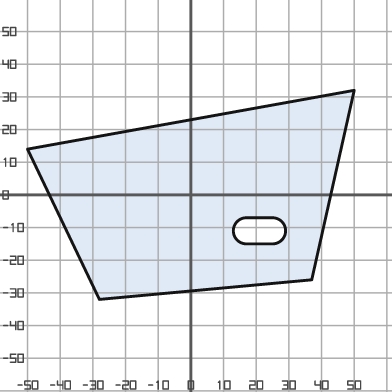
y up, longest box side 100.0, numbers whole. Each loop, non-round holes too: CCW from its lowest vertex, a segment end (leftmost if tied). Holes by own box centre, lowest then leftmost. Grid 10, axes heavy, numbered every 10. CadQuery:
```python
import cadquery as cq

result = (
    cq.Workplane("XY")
    .moveTo(-28.0, -32.0)
    .lineTo(37.0, -26.0)
    .lineTo(50.0, 32.0)
    .lineTo(-50.0, 14.0)
    .close()
    .moveTo(17.0, -15.0)
    .lineTo(25.0, -15.0)
    .threePointArc((29.0, -11.0), (25.0, -7.0))
    .lineTo(17.0, -7.0)
    .threePointArc((13.0, -11.0), (17.0, -15.0))
    .close()
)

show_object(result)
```